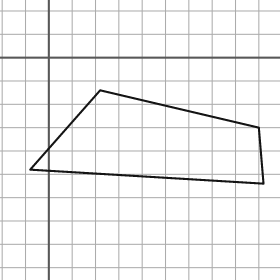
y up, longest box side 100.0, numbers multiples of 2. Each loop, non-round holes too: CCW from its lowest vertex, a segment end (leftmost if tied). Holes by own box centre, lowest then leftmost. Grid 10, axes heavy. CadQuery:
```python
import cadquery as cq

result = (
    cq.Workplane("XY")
    .moveTo(92.0, -54.0)
    .lineTo(90.0, -30.0)
    .lineTo(22.0, -14.0)
    .lineTo(-8.0, -48.0)
    .close()
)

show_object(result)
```